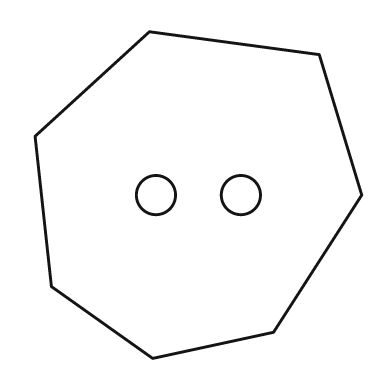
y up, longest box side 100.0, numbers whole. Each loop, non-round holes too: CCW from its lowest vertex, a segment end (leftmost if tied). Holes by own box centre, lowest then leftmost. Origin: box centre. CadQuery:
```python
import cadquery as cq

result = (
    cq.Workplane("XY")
    .moveTo(-14.0, -50.0)
    .lineTo(23.0, -42.0)
    .lineTo(50.0, 0.0)
    .lineTo(37.0, 43.0)
    .lineTo(-15.0, 50.0)
    .lineTo(-50.0, 18.0)
    .lineTo(-45.0, -28.0)
    .close()
    .moveTo(-13.0, 0.0)
    .circle(6.0)
    .moveTo(13.0, 0.0)
    .circle(6.0)
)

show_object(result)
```